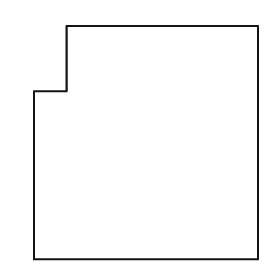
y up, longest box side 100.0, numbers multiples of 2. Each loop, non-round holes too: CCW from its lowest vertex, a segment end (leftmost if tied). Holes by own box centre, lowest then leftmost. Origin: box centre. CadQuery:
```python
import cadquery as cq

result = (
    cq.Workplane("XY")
    .moveTo(-48.0, -50.0)
    .lineTo(48.0, -50.0)
    .lineTo(48.0, 50.0)
    .lineTo(-34.0, 50.0)
    .lineTo(-34.0, 22.0)
    .lineTo(-48.0, 22.0)
    .close()
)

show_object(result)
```